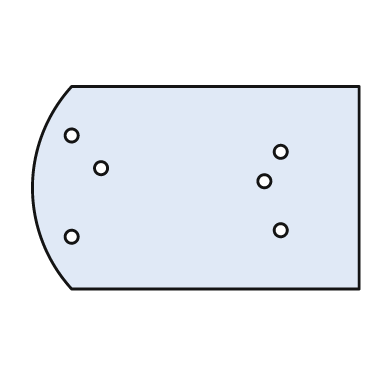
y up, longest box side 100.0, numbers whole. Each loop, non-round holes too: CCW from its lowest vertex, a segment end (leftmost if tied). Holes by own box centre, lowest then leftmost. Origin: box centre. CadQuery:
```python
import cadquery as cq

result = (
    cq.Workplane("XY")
    .moveTo(-38.0, -31.0)
    .lineTo(50.0, -31.0)
    .lineTo(50.0, 31.0)
    .lineTo(-38.0, 31.0)
    .threePointArc((-50.0, 0.0), (-38.0, -31.0))
    .close()
    .moveTo(-38.0, -15.0)
    .circle(2.0)
    .moveTo(26.0, -13.0)
    .circle(2.0)
    .moveTo(21.0, 2.0)
    .circle(2.0)
    .moveTo(-29.0, 6.0)
    .circle(2.0)
    .moveTo(26.0, 11.0)
    .circle(2.0)
    .moveTo(-38.0, 16.0)
    .circle(2.0)
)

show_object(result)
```